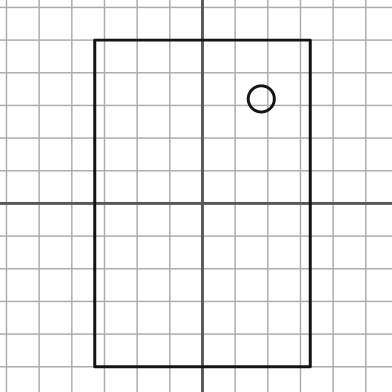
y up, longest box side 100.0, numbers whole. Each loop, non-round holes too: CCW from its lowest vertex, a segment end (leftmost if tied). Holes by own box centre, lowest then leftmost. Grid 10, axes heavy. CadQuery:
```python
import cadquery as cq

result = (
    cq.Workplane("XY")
    .moveTo(-33.0, -50.0)
    .lineTo(33.0, -50.0)
    .lineTo(33.0, 50.0)
    .lineTo(-33.0, 50.0)
    .close()
    .moveTo(18.0, 32.0)
    .circle(4.0)
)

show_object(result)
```